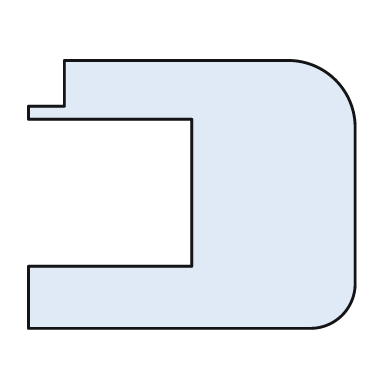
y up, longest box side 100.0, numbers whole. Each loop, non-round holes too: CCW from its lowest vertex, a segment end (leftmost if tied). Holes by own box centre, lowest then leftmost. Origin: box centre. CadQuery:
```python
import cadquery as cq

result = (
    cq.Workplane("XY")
    .moveTo(-50.0, -41.0)
    .lineTo(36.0, -41.0)
    .threePointArc((46.0, -37.0), (50.0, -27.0))
    .lineTo(50.0, 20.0)
    .threePointArc((44.0, 35.0), (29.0, 41.0))
    .lineTo(-39.0, 41.0)
    .lineTo(-39.0, 27.0)
    .lineTo(-50.0, 27.0)
    .lineTo(-50.0, 23.0)
    .lineTo(0.0, 23.0)
    .lineTo(0.0, -22.0)
    .lineTo(-50.0, -22.0)
    .close()
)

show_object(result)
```